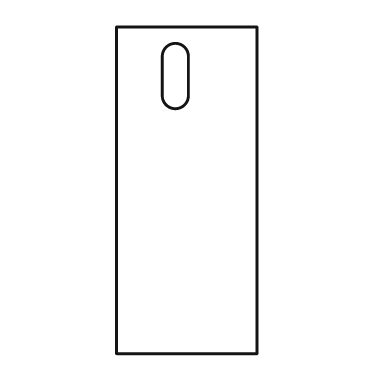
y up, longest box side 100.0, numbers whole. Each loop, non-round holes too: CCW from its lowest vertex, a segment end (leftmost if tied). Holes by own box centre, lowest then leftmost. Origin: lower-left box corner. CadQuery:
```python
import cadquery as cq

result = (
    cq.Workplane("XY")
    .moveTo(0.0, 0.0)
    .lineTo(43.0, 0.0)
    .lineTo(43.0, 100.0)
    .lineTo(0.0, 100.0)
    .close()
    .moveTo(14.0, 79.0)
    .threePointArc((18.0, 75.0), (22.0, 79.0))
    .lineTo(22.0, 91.0)
    .threePointArc((18.0, 95.0), (14.0, 91.0))
    .close()
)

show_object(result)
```